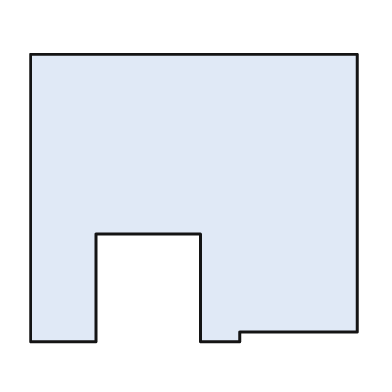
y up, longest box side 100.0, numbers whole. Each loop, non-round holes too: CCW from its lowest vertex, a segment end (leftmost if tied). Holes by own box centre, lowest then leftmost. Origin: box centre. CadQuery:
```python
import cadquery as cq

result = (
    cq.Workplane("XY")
    .moveTo(-50.0, -44.0)
    .lineTo(-30.0, -44.0)
    .lineTo(-30.0, -11.0)
    .lineTo(2.0, -11.0)
    .lineTo(2.0, -44.0)
    .lineTo(14.0, -44.0)
    .lineTo(14.0, -41.0)
    .lineTo(50.0, -41.0)
    .lineTo(50.0, 44.0)
    .lineTo(-50.0, 44.0)
    .close()
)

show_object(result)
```